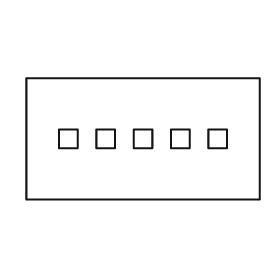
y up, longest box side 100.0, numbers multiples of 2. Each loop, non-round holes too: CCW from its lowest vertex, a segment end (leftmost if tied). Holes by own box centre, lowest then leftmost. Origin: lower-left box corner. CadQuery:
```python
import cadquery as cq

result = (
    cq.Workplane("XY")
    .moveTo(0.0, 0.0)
    .lineTo(100.0, 0.0)
    .lineTo(100.0, 52.0)
    .lineTo(0.0, 52.0)
    .close()
    .moveTo(14.0, 22.0)
    .lineTo(22.0, 22.0)
    .lineTo(22.0, 30.0)
    .lineTo(14.0, 30.0)
    .close()
    .moveTo(30.0, 22.0)
    .lineTo(38.0, 22.0)
    .lineTo(38.0, 30.0)
    .lineTo(30.0, 30.0)
    .close()
    .moveTo(46.0, 22.0)
    .lineTo(54.0, 22.0)
    .lineTo(54.0, 30.0)
    .lineTo(46.0, 30.0)
    .close()
    .moveTo(62.0, 22.0)
    .lineTo(70.0, 22.0)
    .lineTo(70.0, 30.0)
    .lineTo(62.0, 30.0)
    .close()
    .moveTo(78.0, 22.0)
    .lineTo(86.0, 22.0)
    .lineTo(86.0, 30.0)
    .lineTo(78.0, 30.0)
    .close()
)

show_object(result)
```